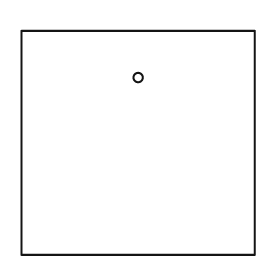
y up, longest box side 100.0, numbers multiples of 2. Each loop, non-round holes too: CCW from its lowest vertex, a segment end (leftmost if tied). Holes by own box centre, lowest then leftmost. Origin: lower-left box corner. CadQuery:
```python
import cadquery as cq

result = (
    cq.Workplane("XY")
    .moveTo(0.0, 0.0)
    .lineTo(100.0, 0.0)
    .lineTo(100.0, 96.0)
    .lineTo(0.0, 96.0)
    .close()
    .moveTo(50.0, 76.0)
    .circle(2.0)
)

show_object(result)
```